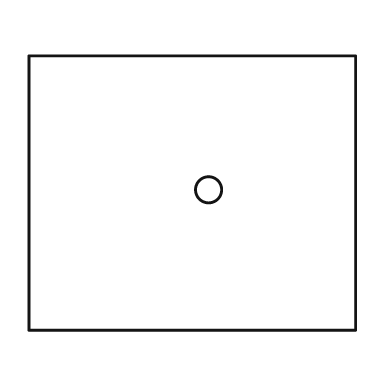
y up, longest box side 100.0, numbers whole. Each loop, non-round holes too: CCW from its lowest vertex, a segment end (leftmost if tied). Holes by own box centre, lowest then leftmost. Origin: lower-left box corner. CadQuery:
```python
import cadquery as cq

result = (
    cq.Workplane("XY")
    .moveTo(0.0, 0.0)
    .lineTo(100.0, 0.0)
    .lineTo(100.0, 84.0)
    .lineTo(0.0, 84.0)
    .close()
    .moveTo(55.0, 43.0)
    .circle(4.0)
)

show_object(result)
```